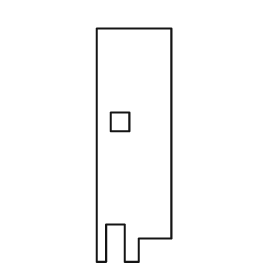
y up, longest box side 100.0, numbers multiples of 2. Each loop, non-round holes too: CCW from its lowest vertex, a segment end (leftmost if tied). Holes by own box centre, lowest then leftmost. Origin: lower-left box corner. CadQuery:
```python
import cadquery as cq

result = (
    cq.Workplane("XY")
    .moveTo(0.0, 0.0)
    .lineTo(4.0, 0.0)
    .lineTo(4.0, 16.0)
    .lineTo(12.0, 16.0)
    .lineTo(12.0, 0.0)
    .lineTo(18.0, 0.0)
    .lineTo(18.0, 10.0)
    .lineTo(32.0, 10.0)
    .lineTo(32.0, 100.0)
    .lineTo(0.0, 100.0)
    .close()
    .moveTo(6.0, 56.0)
    .lineTo(14.0, 56.0)
    .lineTo(14.0, 64.0)
    .lineTo(6.0, 64.0)
    .close()
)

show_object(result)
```